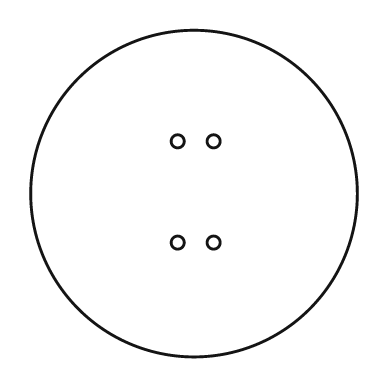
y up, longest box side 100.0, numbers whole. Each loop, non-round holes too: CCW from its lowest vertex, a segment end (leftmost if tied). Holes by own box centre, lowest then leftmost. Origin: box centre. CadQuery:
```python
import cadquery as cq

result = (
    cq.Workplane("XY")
    .moveTo(0.0, 0.0)
    .circle(50.0)
    .moveTo(-5.0, -15.0)
    .circle(2.0)
    .moveTo(6.0, -15.0)
    .circle(2.0)
    .moveTo(-5.0, 16.0)
    .circle(2.0)
    .moveTo(6.0, 16.0)
    .circle(2.0)
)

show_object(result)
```